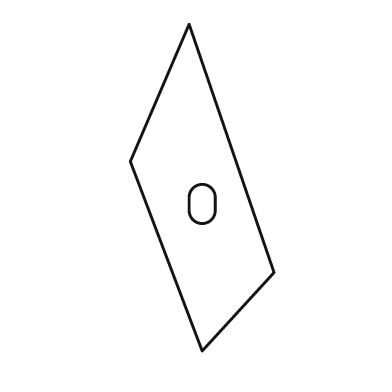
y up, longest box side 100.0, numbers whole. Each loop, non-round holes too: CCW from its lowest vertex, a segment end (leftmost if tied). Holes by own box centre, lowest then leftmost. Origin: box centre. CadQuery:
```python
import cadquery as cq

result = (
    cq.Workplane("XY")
    .moveTo(0.0, -50.0)
    .lineTo(22.0, -26.0)
    .lineTo(-4.0, 50.0)
    .lineTo(-22.0, 8.0)
    .close()
    .moveTo(-4.0, -7.0)
    .threePointArc((0.0, -11.0), (4.0, -7.0))
    .lineTo(4.0, -3.0)
    .threePointArc((0.0, 1.0), (-4.0, -3.0))
    .close()
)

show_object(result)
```